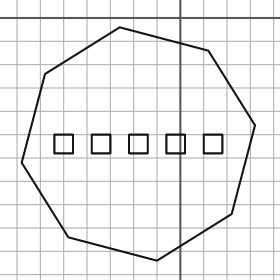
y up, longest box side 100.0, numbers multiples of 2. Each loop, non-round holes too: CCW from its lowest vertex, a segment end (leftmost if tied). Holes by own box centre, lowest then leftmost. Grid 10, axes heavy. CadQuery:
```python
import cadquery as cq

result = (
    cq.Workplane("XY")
    .moveTo(-10.0, -104.0)
    .lineTo(22.0, -84.0)
    .lineTo(32.0, -46.0)
    .lineTo(12.0, -14.0)
    .lineTo(-26.0, -4.0)
    .lineTo(-58.0, -24.0)
    .lineTo(-68.0, -62.0)
    .lineTo(-48.0, -94.0)
    .close()
    .moveTo(-54.0, -58.0)
    .lineTo(-46.0, -58.0)
    .lineTo(-46.0, -50.0)
    .lineTo(-54.0, -50.0)
    .close()
    .moveTo(-38.0, -58.0)
    .lineTo(-30.0, -58.0)
    .lineTo(-30.0, -50.0)
    .lineTo(-38.0, -50.0)
    .close()
    .moveTo(-22.0, -58.0)
    .lineTo(-14.0, -58.0)
    .lineTo(-14.0, -50.0)
    .lineTo(-22.0, -50.0)
    .close()
    .moveTo(-6.0, -58.0)
    .lineTo(2.0, -58.0)
    .lineTo(2.0, -50.0)
    .lineTo(-6.0, -50.0)
    .close()
    .moveTo(10.0, -58.0)
    .lineTo(18.0, -58.0)
    .lineTo(18.0, -50.0)
    .lineTo(10.0, -50.0)
    .close()
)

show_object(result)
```